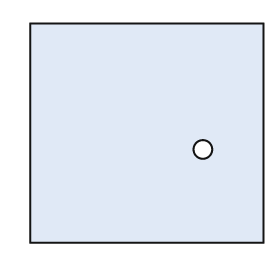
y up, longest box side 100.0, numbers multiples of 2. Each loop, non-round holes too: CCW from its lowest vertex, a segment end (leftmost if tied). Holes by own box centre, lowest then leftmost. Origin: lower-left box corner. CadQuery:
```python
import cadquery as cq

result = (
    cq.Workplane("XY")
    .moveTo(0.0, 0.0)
    .lineTo(100.0, 0.0)
    .lineTo(100.0, 94.0)
    .lineTo(0.0, 94.0)
    .close()
    .moveTo(74.0, 40.0)
    .circle(4.0)
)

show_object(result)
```